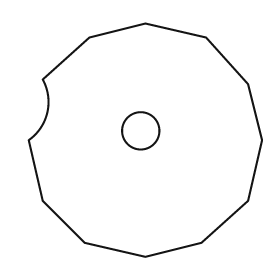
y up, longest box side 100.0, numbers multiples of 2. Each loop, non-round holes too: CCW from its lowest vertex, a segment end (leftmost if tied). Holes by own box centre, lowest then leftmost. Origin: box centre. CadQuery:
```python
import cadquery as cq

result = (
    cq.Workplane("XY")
    .moveTo(0.0, -50.0)
    .lineTo(24.0, -44.0)
    .lineTo(44.0, -26.0)
    .lineTo(50.0, 0.0)
    .lineTo(44.0, 24.0)
    .lineTo(26.0, 44.0)
    .lineTo(0.0, 50.0)
    .lineTo(-24.0, 44.0)
    .lineTo(-44.0, 26.0)
    .threePointArc((-42.0, 12.0), (-50.0, 0.0))
    .lineTo(-44.0, -26.0)
    .lineTo(-26.0, -44.0)
    .close()
    .moveTo(-2.0, 4.0)
    .circle(8.0)
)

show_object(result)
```